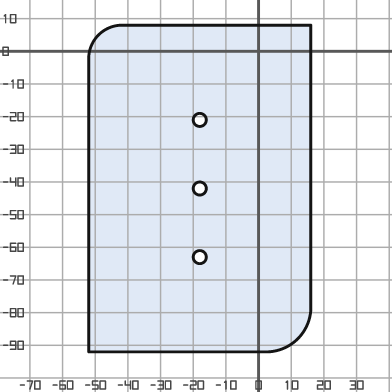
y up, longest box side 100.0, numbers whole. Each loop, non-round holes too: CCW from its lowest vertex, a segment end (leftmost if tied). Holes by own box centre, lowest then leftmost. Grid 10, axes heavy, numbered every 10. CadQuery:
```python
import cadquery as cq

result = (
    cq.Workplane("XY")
    .moveTo(-52.0, -92.0)
    .lineTo(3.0, -92.0)
    .threePointArc((12.0, -88.0), (16.0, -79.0))
    .lineTo(16.0, 8.0)
    .lineTo(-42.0, 8.0)
    .threePointArc((-49.0, 5.0), (-52.0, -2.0))
    .close()
    .moveTo(-18.0, -63.0)
    .circle(2.0)
    .moveTo(-18.0, -42.0)
    .circle(2.0)
    .moveTo(-18.0, -21.0)
    .circle(2.0)
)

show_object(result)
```